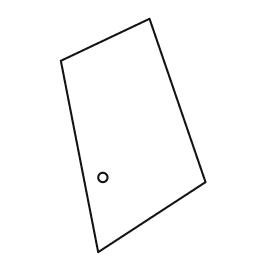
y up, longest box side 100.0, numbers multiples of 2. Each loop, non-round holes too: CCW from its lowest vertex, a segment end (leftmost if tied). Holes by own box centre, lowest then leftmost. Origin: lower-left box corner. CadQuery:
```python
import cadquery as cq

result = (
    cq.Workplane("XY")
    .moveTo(16.0, 0.0)
    .lineTo(62.0, 30.0)
    .lineTo(38.0, 100.0)
    .lineTo(0.0, 82.0)
    .close()
    .moveTo(18.0, 32.0)
    .circle(2.0)
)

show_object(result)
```